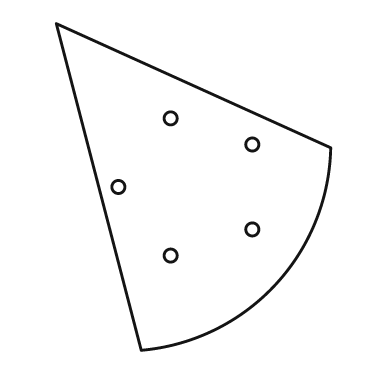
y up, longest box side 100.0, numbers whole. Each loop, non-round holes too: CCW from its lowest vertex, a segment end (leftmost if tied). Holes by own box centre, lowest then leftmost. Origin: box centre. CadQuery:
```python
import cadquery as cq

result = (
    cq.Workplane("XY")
    .moveTo(-16.0, -50.0)
    .threePointArc((25.0, -30.0), (42.0, 12.0))
    .lineTo(-42.0, 50.0)
    .close()
    .moveTo(-7.0, -21.0)
    .circle(2.0)
    .moveTo(18.0, -13.0)
    .circle(2.0)
    .moveTo(-23.0, 0.0)
    .circle(2.0)
    .moveTo(18.0, 13.0)
    .circle(2.0)
    .moveTo(-7.0, 21.0)
    .circle(2.0)
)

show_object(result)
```